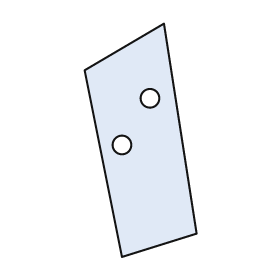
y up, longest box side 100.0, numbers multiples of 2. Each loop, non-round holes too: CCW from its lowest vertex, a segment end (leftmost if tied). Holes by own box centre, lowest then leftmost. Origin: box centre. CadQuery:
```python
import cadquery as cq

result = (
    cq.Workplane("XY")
    .moveTo(-8.0, -50.0)
    .lineTo(24.0, -40.0)
    .lineTo(10.0, 50.0)
    .lineTo(-24.0, 30.0)
    .close()
    .moveTo(-8.0, -2.0)
    .circle(4.0)
    .moveTo(4.0, 18.0)
    .circle(4.0)
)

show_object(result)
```